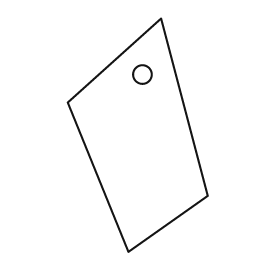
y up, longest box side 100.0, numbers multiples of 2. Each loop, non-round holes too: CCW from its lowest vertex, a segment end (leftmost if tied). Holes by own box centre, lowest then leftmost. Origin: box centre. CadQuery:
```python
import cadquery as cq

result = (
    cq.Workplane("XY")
    .moveTo(-4.0, -50.0)
    .lineTo(30.0, -26.0)
    .lineTo(10.0, 50.0)
    .lineTo(-30.0, 14.0)
    .close()
    .moveTo(2.0, 26.0)
    .circle(4.0)
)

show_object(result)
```